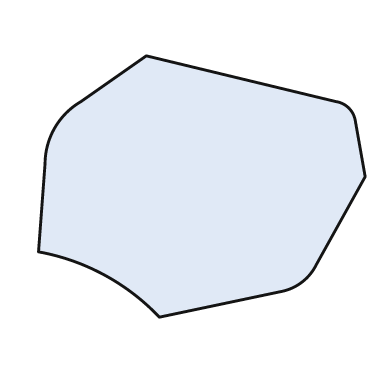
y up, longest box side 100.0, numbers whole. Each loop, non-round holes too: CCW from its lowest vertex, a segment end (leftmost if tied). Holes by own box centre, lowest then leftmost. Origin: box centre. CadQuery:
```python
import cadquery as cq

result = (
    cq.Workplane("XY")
    .moveTo(-13.0, -40.0)
    .lineTo(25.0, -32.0)
    .threePointArc((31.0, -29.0), (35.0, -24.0))
    .lineTo(50.0, 3.0)
    .lineTo(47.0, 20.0)
    .threePointArc((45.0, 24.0), (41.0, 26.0))
    .lineTo(-17.0, 40.0)
    .lineTo(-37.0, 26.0)
    .threePointArc((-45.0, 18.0), (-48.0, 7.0))
    .lineTo(-50.0, -20.0)
    .threePointArc((-30.0, -27.0), (-13.0, -40.0))
    .close()
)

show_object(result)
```